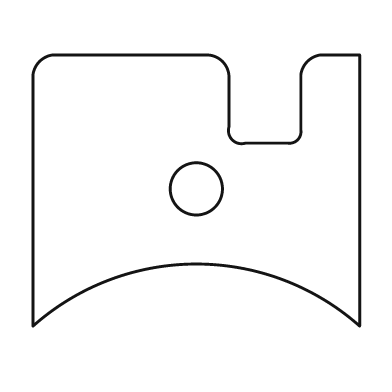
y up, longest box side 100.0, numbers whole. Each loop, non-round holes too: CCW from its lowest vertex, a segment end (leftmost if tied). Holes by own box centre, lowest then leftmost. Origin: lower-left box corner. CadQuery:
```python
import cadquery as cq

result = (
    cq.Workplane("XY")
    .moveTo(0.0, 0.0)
    .threePointArc((50.0, 19.0), (100.0, 0.0))
    .lineTo(100.0, 83.0)
    .lineTo(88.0, 83.0)
    .threePointArc((84.0, 81.0), (82.0, 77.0))
    .lineTo(82.0, 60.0)
    .threePointArc((81.0, 57.0), (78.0, 56.0))
    .lineTo(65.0, 56.0)
    .threePointArc((61.0, 57.0), (60.0, 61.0))
    .lineTo(60.0, 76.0)
    .threePointArc((58.0, 81.0), (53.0, 83.0))
    .lineTo(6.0, 83.0)
    .threePointArc((2.0, 81.0), (0.0, 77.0))
    .close()
    .moveTo(50.0, 42.0)
    .circle(8.0)
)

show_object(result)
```